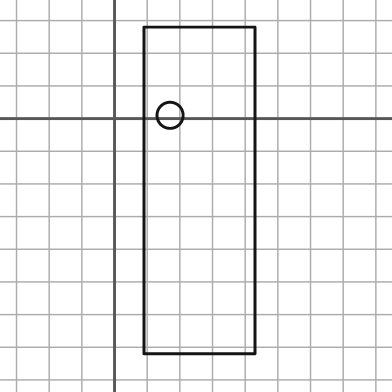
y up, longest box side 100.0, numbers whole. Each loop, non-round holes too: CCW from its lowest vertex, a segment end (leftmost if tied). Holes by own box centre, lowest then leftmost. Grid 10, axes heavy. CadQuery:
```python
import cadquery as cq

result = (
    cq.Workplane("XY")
    .moveTo(9.0, -72.0)
    .lineTo(43.0, -72.0)
    .lineTo(43.0, 28.0)
    .lineTo(9.0, 28.0)
    .close()
    .moveTo(17.0, 1.0)
    .circle(4.0)
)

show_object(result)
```